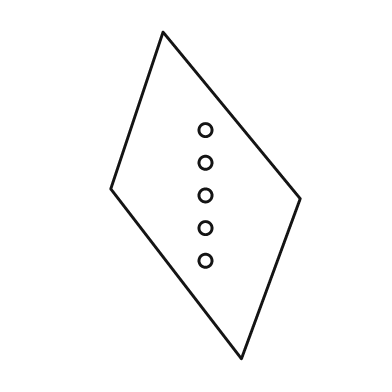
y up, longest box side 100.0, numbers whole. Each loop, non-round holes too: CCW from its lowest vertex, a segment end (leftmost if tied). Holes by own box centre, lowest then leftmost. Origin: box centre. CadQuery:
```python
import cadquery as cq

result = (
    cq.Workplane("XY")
    .moveTo(11.0, -50.0)
    .lineTo(29.0, -1.0)
    .lineTo(-13.0, 50.0)
    .lineTo(-29.0, 2.0)
    .close()
    .moveTo(0.0, -20.0)
    .circle(2.0)
    .moveTo(0.0, -10.0)
    .circle(2.0)
    .moveTo(0.0, 0.0)
    .circle(2.0)
    .moveTo(0.0, 10.0)
    .circle(2.0)
    .moveTo(0.0, 20.0)
    .circle(2.0)
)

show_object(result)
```